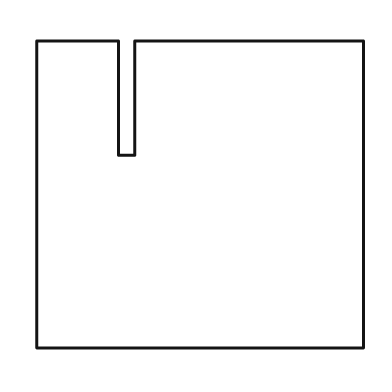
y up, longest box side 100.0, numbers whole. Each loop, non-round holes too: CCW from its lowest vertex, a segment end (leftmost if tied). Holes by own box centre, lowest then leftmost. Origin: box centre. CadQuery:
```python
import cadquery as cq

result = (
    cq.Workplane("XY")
    .moveTo(-50.0, -47.0)
    .lineTo(50.0, -47.0)
    .lineTo(50.0, 47.0)
    .lineTo(-20.0, 47.0)
    .lineTo(-20.0, 12.0)
    .lineTo(-25.0, 12.0)
    .lineTo(-25.0, 47.0)
    .lineTo(-50.0, 47.0)
    .close()
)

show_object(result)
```